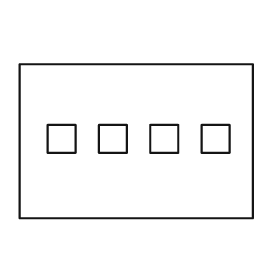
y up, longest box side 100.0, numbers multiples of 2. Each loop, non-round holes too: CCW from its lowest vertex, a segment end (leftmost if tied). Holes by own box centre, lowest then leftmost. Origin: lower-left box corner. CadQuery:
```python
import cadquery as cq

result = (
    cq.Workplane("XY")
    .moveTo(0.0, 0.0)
    .lineTo(100.0, 0.0)
    .lineTo(100.0, 66.0)
    .lineTo(0.0, 66.0)
    .close()
    .moveTo(12.0, 28.0)
    .lineTo(24.0, 28.0)
    .lineTo(24.0, 40.0)
    .lineTo(12.0, 40.0)
    .close()
    .moveTo(34.0, 28.0)
    .lineTo(46.0, 28.0)
    .lineTo(46.0, 40.0)
    .lineTo(34.0, 40.0)
    .close()
    .moveTo(56.0, 28.0)
    .lineTo(68.0, 28.0)
    .lineTo(68.0, 40.0)
    .lineTo(56.0, 40.0)
    .close()
    .moveTo(78.0, 28.0)
    .lineTo(90.0, 28.0)
    .lineTo(90.0, 40.0)
    .lineTo(78.0, 40.0)
    .close()
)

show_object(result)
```